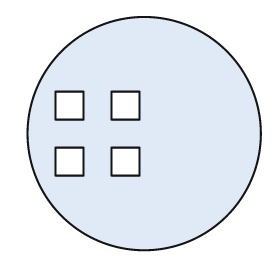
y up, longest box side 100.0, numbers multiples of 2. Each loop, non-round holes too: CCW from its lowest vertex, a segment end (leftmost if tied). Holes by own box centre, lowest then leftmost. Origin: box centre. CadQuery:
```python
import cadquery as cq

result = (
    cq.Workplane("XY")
    .moveTo(0.0, 0.0)
    .circle(50.0)
    .moveTo(-38.0, -18.0)
    .lineTo(-26.0, -18.0)
    .lineTo(-26.0, -6.0)
    .lineTo(-38.0, -6.0)
    .close()
    .moveTo(-14.0, -18.0)
    .lineTo(-2.0, -18.0)
    .lineTo(-2.0, -6.0)
    .lineTo(-14.0, -6.0)
    .close()
    .moveTo(-38.0, 6.0)
    .lineTo(-26.0, 6.0)
    .lineTo(-26.0, 18.0)
    .lineTo(-38.0, 18.0)
    .close()
    .moveTo(-14.0, 6.0)
    .lineTo(-2.0, 6.0)
    .lineTo(-2.0, 18.0)
    .lineTo(-14.0, 18.0)
    .close()
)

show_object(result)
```